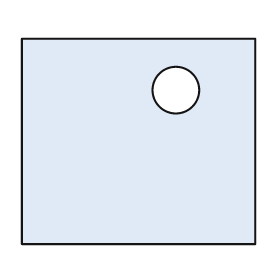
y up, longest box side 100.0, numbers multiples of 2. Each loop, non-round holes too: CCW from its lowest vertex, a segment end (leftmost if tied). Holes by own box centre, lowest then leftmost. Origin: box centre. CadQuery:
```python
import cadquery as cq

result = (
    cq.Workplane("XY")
    .moveTo(-50.0, -44.0)
    .lineTo(50.0, -44.0)
    .lineTo(50.0, 44.0)
    .lineTo(-50.0, 44.0)
    .close()
    .moveTo(16.0, 22.0)
    .circle(10.0)
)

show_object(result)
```